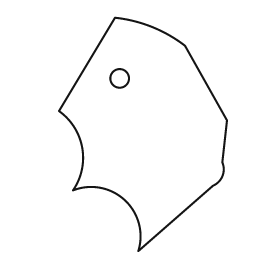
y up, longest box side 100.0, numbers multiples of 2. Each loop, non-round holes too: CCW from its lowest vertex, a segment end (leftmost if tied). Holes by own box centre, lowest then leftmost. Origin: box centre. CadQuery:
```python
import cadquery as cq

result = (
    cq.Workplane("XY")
    .moveTo(-2.0, -50.0)
    .lineTo(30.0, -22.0)
    .threePointArc((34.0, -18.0), (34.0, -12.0))
    .lineTo(36.0, 6.0)
    .lineTo(18.0, 38.0)
    .threePointArc((4.0, 46.0), (-12.0, 50.0))
    .lineTo(-36.0, 10.0)
    .threePointArc((-26.0, -6.0), (-30.0, -24.0))
    .threePointArc((-8.0, -28.0), (-2.0, -50.0))
    .close()
    .moveTo(-10.0, 24.0)
    .circle(4.0)
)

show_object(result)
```